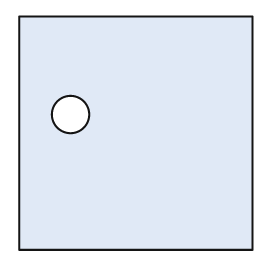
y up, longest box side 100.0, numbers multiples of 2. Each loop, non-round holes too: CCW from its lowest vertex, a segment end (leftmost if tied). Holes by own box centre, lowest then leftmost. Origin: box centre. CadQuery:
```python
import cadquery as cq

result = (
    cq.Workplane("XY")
    .moveTo(-50.0, -50.0)
    .lineTo(50.0, -50.0)
    .lineTo(50.0, 50.0)
    .lineTo(-50.0, 50.0)
    .close()
    .moveTo(-28.0, 8.0)
    .circle(8.0)
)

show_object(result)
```